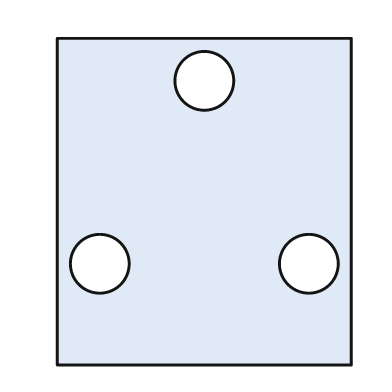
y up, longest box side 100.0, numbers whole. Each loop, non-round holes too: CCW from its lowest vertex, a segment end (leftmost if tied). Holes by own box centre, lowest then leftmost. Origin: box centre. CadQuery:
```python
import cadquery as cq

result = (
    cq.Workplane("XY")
    .moveTo(-45.0, -50.0)
    .lineTo(45.0, -50.0)
    .lineTo(45.0, 50.0)
    .lineTo(-45.0, 50.0)
    .close()
    .moveTo(-32.0, -19.0)
    .circle(9.0)
    .moveTo(32.0, -19.0)
    .circle(9.0)
    .moveTo(0.0, 37.0)
    .circle(9.0)
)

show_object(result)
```